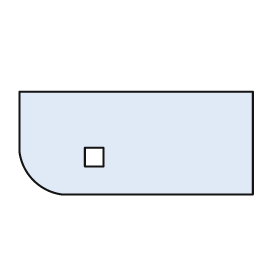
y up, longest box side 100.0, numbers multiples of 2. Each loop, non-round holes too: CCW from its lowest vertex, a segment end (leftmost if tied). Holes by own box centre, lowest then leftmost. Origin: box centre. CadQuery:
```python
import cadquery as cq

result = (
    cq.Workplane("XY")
    .moveTo(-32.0, -22.0)
    .lineTo(50.0, -22.0)
    .lineTo(50.0, 22.0)
    .lineTo(-50.0, 22.0)
    .lineTo(-50.0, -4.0)
    .threePointArc((-44.0, -16.0), (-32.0, -22.0))
    .close()
    .moveTo(-22.0, -10.0)
    .lineTo(-14.0, -10.0)
    .lineTo(-14.0, -2.0)
    .lineTo(-22.0, -2.0)
    .close()
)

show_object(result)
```